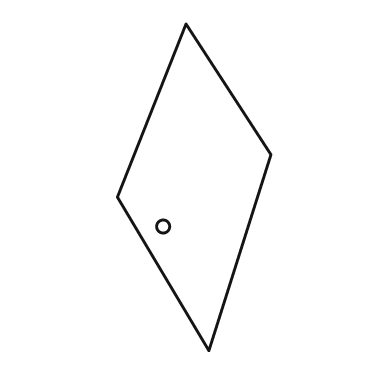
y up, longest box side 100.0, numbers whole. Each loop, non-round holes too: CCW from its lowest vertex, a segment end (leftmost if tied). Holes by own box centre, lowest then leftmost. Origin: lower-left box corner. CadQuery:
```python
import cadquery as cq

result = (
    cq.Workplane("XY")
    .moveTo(28.0, 0.0)
    .lineTo(47.0, 60.0)
    .lineTo(21.0, 100.0)
    .lineTo(0.0, 47.0)
    .close()
    .moveTo(14.0, 38.0)
    .circle(2.0)
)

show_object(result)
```